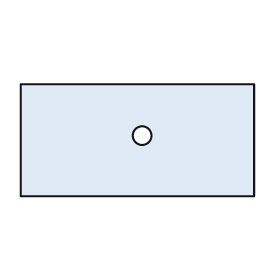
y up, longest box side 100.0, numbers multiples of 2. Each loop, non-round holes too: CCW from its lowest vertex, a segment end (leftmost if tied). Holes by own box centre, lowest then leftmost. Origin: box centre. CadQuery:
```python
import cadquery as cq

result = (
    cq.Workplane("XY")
    .moveTo(-50.0, -24.0)
    .lineTo(50.0, -24.0)
    .lineTo(50.0, 24.0)
    .lineTo(-50.0, 24.0)
    .close()
    .moveTo(2.0, 2.0)
    .circle(4.0)
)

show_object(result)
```